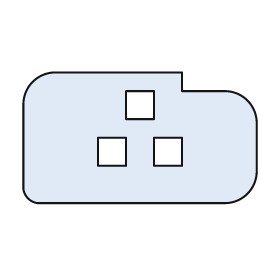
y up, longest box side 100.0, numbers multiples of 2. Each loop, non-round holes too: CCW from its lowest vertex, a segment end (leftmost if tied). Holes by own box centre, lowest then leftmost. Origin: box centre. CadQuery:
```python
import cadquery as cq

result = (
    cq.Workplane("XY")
    .moveTo(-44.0, -28.0)
    .lineTo(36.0, -28.0)
    .threePointArc((46.0, -24.0), (50.0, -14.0))
    .lineTo(50.0, 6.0)
    .threePointArc((46.0, 16.0), (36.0, 20.0))
    .lineTo(18.0, 20.0)
    .lineTo(18.0, 28.0)
    .lineTo(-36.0, 28.0)
    .threePointArc((-46.0, 24.0), (-50.0, 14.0))
    .lineTo(-50.0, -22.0)
    .threePointArc((-48.0, -26.0), (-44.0, -28.0))
    .close()
    .moveTo(-18.0, -12.0)
    .lineTo(-6.0, -12.0)
    .lineTo(-6.0, 0.0)
    .lineTo(-18.0, 0.0)
    .close()
    .moveTo(6.0, -12.0)
    .lineTo(18.0, -12.0)
    .lineTo(18.0, 0.0)
    .lineTo(6.0, 0.0)
    .close()
    .moveTo(-6.0, 8.0)
    .lineTo(6.0, 8.0)
    .lineTo(6.0, 20.0)
    .lineTo(-6.0, 20.0)
    .close()
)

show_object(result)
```